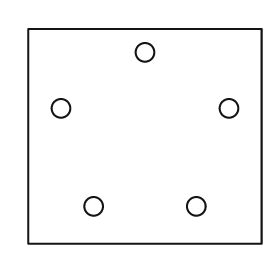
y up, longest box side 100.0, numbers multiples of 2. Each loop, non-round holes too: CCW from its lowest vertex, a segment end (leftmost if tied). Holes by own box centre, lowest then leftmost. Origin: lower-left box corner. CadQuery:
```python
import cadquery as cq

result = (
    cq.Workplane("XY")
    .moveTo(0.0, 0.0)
    .lineTo(100.0, 0.0)
    .lineTo(100.0, 92.0)
    .lineTo(0.0, 92.0)
    .close()
    .moveTo(28.0, 16.0)
    .circle(4.0)
    .moveTo(72.0, 16.0)
    .circle(4.0)
    .moveTo(14.0, 58.0)
    .circle(4.0)
    .moveTo(86.0, 58.0)
    .circle(4.0)
    .moveTo(50.0, 82.0)
    .circle(4.0)
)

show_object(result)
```